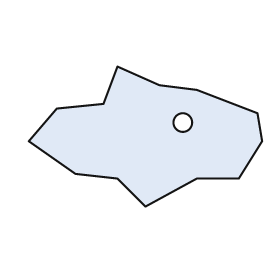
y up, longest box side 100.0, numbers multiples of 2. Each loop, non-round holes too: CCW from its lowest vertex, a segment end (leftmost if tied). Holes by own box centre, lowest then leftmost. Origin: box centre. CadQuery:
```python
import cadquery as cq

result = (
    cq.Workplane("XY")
    .moveTo(0.0, -30.0)
    .lineTo(22.0, -18.0)
    .lineTo(40.0, -18.0)
    .lineTo(50.0, -2.0)
    .lineTo(48.0, 10.0)
    .lineTo(22.0, 20.0)
    .lineTo(6.0, 22.0)
    .lineTo(-12.0, 30.0)
    .lineTo(-18.0, 14.0)
    .lineTo(-38.0, 12.0)
    .lineTo(-50.0, -2.0)
    .lineTo(-30.0, -16.0)
    .lineTo(-12.0, -18.0)
    .close()
    .moveTo(16.0, 6.0)
    .circle(4.0)
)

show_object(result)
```